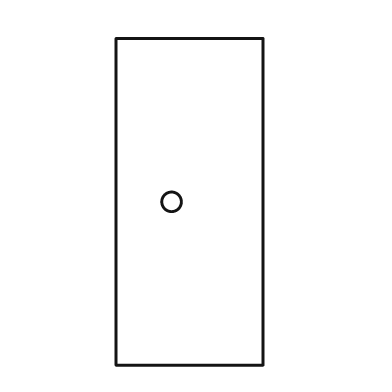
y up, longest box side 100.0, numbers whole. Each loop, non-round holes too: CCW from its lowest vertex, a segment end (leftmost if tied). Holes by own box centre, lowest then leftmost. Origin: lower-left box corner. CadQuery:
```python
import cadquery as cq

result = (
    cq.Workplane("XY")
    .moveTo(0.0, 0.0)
    .lineTo(45.0, 0.0)
    .lineTo(45.0, 100.0)
    .lineTo(0.0, 100.0)
    .close()
    .moveTo(17.0, 50.0)
    .circle(3.0)
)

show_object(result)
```